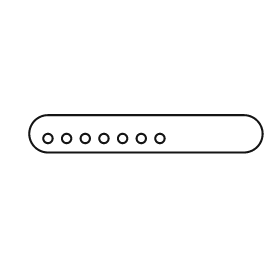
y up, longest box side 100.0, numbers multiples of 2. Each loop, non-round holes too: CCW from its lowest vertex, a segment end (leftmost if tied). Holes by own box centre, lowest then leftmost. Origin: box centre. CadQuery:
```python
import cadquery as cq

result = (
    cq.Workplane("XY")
    .moveTo(-42.0, -8.0)
    .lineTo(42.0, -8.0)
    .threePointArc((50.0, 0.0), (42.0, 8.0))
    .lineTo(-42.0, 8.0)
    .threePointArc((-50.0, 0.0), (-42.0, -8.0))
    .close()
    .moveTo(-42.0, -2.0)
    .circle(2.0)
    .moveTo(-34.0, -2.0)
    .circle(2.0)
    .moveTo(-26.0, -2.0)
    .circle(2.0)
    .moveTo(-18.0, -2.0)
    .circle(2.0)
    .moveTo(-10.0, -2.0)
    .circle(2.0)
    .moveTo(-2.0, -2.0)
    .circle(2.0)
    .moveTo(6.0, -2.0)
    .circle(2.0)
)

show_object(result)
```